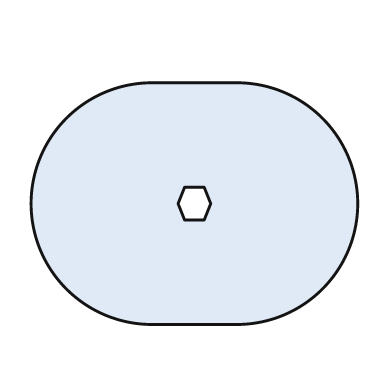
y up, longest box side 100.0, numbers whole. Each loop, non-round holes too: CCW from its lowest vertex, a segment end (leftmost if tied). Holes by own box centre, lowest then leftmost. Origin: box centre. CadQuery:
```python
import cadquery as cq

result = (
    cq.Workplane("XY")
    .moveTo(-13.0, -37.0)
    .lineTo(13.0, -37.0)
    .threePointArc((50.0, 0.0), (13.0, 37.0))
    .lineTo(-13.0, 37.0)
    .threePointArc((-50.0, 0.0), (-13.0, -37.0))
    .close()
    .moveTo(-3.0, -5.0)
    .lineTo(3.0, -5.0)
    .lineTo(5.0, 0.0)
    .lineTo(3.0, 5.0)
    .lineTo(-3.0, 5.0)
    .lineTo(-5.0, 0.0)
    .close()
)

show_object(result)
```